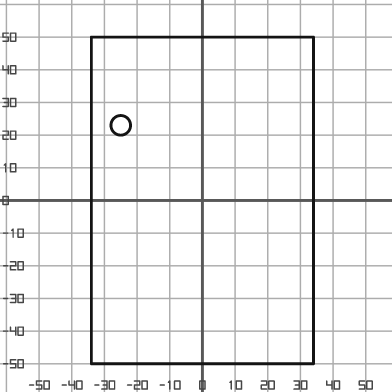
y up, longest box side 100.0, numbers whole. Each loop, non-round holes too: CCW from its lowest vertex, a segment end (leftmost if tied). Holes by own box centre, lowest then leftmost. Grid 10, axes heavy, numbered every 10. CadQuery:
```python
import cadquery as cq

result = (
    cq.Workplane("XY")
    .moveTo(-34.0, -50.0)
    .lineTo(34.0, -50.0)
    .lineTo(34.0, 50.0)
    .lineTo(-34.0, 50.0)
    .close()
    .moveTo(-25.0, 23.0)
    .circle(3.0)
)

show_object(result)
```